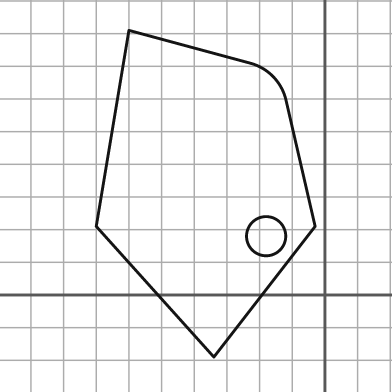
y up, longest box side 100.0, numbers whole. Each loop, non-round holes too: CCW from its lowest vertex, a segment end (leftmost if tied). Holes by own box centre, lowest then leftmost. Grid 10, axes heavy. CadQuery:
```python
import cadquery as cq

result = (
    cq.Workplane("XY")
    .moveTo(-34.0, -19.0)
    .lineTo(-3.0, 21.0)
    .lineTo(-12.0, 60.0)
    .threePointArc((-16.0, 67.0), (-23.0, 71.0))
    .lineTo(-60.0, 81.0)
    .lineTo(-70.0, 21.0)
    .close()
    .moveTo(-18.0, 18.0)
    .circle(6.0)
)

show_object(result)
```